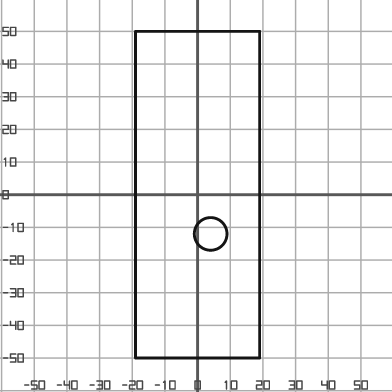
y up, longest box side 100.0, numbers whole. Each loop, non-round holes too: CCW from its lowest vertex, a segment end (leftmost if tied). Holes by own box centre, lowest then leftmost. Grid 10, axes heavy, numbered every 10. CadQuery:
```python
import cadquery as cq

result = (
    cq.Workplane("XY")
    .moveTo(-19.0, -50.0)
    .lineTo(19.0, -50.0)
    .lineTo(19.0, 50.0)
    .lineTo(-19.0, 50.0)
    .close()
    .moveTo(4.0, -12.0)
    .circle(5.0)
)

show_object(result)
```